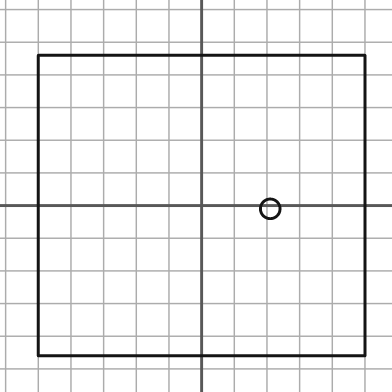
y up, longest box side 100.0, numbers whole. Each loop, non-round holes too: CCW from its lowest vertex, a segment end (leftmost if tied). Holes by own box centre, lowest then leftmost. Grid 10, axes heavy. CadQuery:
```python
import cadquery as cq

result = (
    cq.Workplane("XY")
    .moveTo(-50.0, -46.0)
    .lineTo(50.0, -46.0)
    .lineTo(50.0, 46.0)
    .lineTo(-50.0, 46.0)
    .close()
    .moveTo(21.0, -1.0)
    .circle(3.0)
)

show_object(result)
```